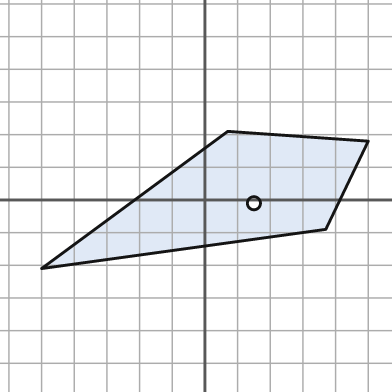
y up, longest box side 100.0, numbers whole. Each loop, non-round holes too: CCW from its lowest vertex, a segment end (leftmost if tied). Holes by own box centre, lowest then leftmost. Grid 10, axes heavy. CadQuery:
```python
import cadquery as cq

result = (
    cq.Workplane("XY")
    .moveTo(-50.0, -21.0)
    .lineTo(37.0, -9.0)
    .lineTo(50.0, 18.0)
    .lineTo(7.0, 21.0)
    .close()
    .moveTo(15.0, -1.0)
    .circle(2.0)
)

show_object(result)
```